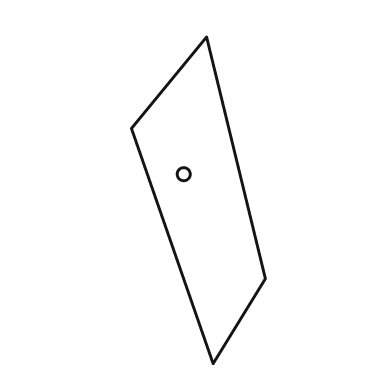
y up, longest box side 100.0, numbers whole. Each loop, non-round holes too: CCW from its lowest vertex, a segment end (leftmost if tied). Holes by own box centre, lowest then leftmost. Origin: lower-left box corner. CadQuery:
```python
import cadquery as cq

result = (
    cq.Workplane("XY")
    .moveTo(25.0, 0.0)
    .lineTo(41.0, 26.0)
    .lineTo(23.0, 100.0)
    .lineTo(0.0, 72.0)
    .close()
    .moveTo(16.0, 58.0)
    .circle(2.0)
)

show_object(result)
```